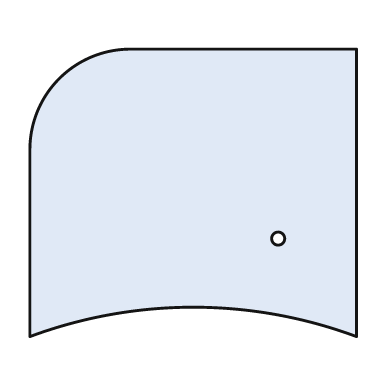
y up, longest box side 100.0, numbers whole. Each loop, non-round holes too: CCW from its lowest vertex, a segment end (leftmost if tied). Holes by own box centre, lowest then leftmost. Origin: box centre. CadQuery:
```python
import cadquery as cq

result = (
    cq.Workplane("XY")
    .moveTo(-50.0, -44.0)
    .threePointArc((0.0, -35.0), (50.0, -44.0))
    .lineTo(50.0, 44.0)
    .lineTo(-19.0, 44.0)
    .threePointArc((-41.0, 35.0), (-50.0, 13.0))
    .close()
    .moveTo(26.0, -14.0)
    .circle(2.0)
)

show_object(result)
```